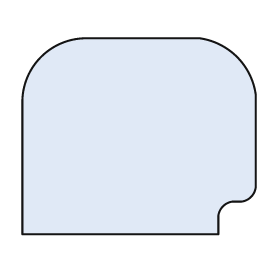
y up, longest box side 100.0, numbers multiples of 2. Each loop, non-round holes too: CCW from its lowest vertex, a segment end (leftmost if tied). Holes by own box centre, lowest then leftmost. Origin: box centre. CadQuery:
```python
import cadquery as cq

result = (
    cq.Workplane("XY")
    .moveTo(-50.0, -42.0)
    .lineTo(34.0, -42.0)
    .lineTo(34.0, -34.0)
    .threePointArc((36.0, -30.0), (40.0, -28.0))
    .lineTo(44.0, -28.0)
    .threePointArc((48.0, -26.0), (50.0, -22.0))
    .lineTo(50.0, 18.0)
    .threePointArc((42.0, 34.0), (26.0, 42.0))
    .lineTo(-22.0, 42.0)
    .threePointArc((-42.0, 34.0), (-50.0, 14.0))
    .close()
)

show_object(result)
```